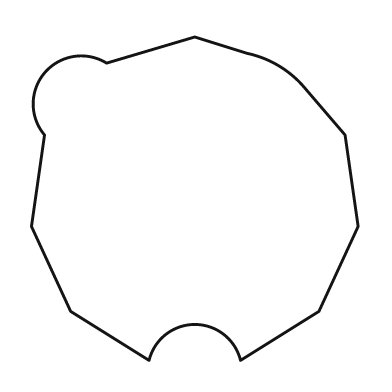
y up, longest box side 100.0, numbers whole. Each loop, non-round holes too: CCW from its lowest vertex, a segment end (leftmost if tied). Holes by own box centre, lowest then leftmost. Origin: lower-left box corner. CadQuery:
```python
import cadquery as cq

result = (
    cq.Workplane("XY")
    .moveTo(36.0, 0.0)
    .threePointArc((50.0, 11.0), (64.0, 0.0))
    .lineTo(88.0, 15.0)
    .lineTo(100.0, 41.0)
    .lineTo(96.0, 69.0)
    .lineTo(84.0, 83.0)
    .threePointArc((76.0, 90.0), (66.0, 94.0))
    .lineTo(50.0, 99.0)
    .lineTo(23.0, 91.0)
    .threePointArc((4.0, 88.0), (4.0, 69.0))
    .lineTo(0.0, 41.0)
    .lineTo(12.0, 15.0)
    .close()
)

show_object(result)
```